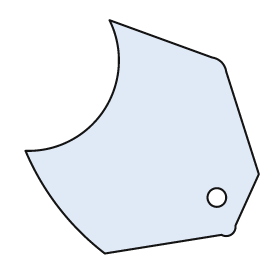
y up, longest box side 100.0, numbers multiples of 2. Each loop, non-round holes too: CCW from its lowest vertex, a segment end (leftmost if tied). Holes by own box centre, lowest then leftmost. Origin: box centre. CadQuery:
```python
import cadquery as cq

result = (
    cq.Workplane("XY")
    .moveTo(-16.0, -50.0)
    .lineTo(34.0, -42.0)
    .threePointArc((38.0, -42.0), (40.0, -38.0))
    .lineTo(50.0, -16.0)
    .lineTo(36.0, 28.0)
    .threePointArc((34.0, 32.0), (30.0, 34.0))
    .lineTo(-14.0, 50.0)
    .threePointArc((-16.0, 12.0), (-50.0, -6.0))
    .threePointArc((-36.0, -30.0), (-16.0, -50.0))
    .close()
    .moveTo(32.0, -26.0)
    .circle(4.0)
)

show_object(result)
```